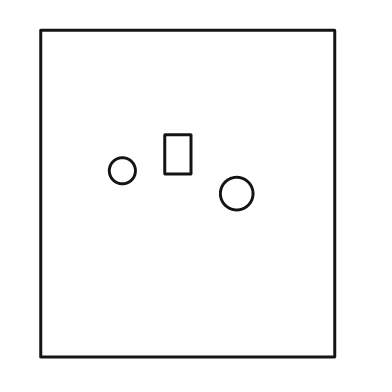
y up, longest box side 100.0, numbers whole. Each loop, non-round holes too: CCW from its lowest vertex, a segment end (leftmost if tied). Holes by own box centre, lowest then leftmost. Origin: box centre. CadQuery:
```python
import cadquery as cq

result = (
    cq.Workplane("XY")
    .moveTo(-45.0, -50.0)
    .lineTo(45.0, -50.0)
    .lineTo(45.0, 50.0)
    .lineTo(-45.0, 50.0)
    .close()
    .moveTo(15.0, 0.0)
    .circle(5.0)
    .moveTo(-20.0, 7.0)
    .circle(4.0)
    .moveTo(-7.0, 6.0)
    .lineTo(1.0, 6.0)
    .lineTo(1.0, 18.0)
    .lineTo(-7.0, 18.0)
    .close()
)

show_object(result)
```